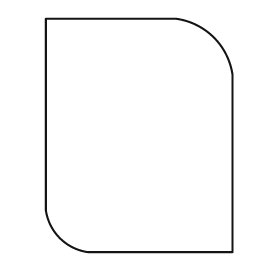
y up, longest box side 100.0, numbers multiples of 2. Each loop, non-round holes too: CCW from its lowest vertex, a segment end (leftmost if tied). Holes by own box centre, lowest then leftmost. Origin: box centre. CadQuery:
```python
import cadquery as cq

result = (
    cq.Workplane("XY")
    .moveTo(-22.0, -50.0)
    .lineTo(40.0, -50.0)
    .lineTo(40.0, 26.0)
    .threePointArc((32.0, 42.0), (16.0, 50.0))
    .lineTo(-40.0, 50.0)
    .lineTo(-40.0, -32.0)
    .threePointArc((-34.0, -44.0), (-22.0, -50.0))
    .close()
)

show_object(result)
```